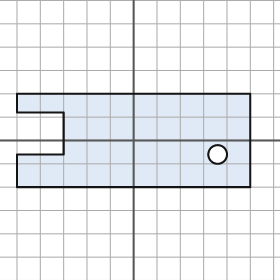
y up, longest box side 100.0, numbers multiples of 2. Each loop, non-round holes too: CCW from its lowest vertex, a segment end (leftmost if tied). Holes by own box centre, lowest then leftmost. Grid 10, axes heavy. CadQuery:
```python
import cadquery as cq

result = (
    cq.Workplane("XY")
    .moveTo(-50.0, -20.0)
    .lineTo(50.0, -20.0)
    .lineTo(50.0, 20.0)
    .lineTo(-50.0, 20.0)
    .lineTo(-50.0, 12.0)
    .lineTo(-30.0, 12.0)
    .lineTo(-30.0, -6.0)
    .lineTo(-50.0, -6.0)
    .close()
    .moveTo(36.0, -6.0)
    .circle(4.0)
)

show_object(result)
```